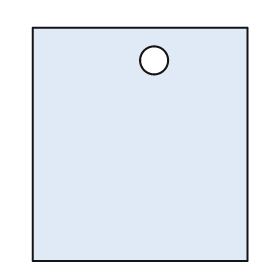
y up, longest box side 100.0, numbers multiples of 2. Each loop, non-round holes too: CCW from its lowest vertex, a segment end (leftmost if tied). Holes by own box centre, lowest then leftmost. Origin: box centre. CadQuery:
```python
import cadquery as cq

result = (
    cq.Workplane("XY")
    .moveTo(-46.0, -50.0)
    .lineTo(46.0, -50.0)
    .lineTo(46.0, 50.0)
    .lineTo(-46.0, 50.0)
    .close()
    .moveTo(6.0, 36.0)
    .circle(6.0)
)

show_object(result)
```